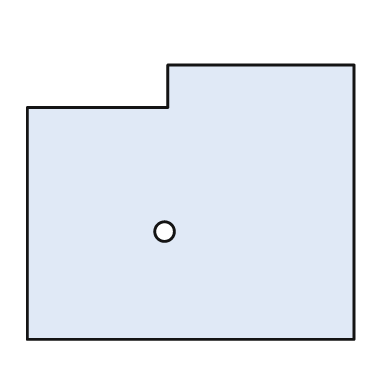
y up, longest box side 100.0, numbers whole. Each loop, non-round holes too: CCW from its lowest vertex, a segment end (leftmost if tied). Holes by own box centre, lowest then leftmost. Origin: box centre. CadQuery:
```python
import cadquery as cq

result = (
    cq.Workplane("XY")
    .moveTo(-50.0, -42.0)
    .lineTo(50.0, -42.0)
    .lineTo(50.0, 42.0)
    .lineTo(-7.0, 42.0)
    .lineTo(-7.0, 29.0)
    .lineTo(-50.0, 29.0)
    .close()
    .moveTo(-8.0, -9.0)
    .circle(3.0)
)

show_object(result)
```